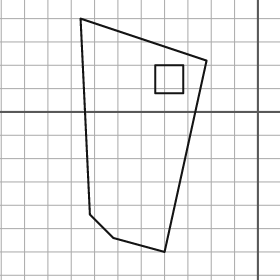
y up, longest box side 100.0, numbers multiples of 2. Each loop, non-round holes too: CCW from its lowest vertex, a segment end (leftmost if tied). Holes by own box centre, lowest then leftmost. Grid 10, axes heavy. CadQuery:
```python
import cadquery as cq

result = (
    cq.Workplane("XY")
    .moveTo(-40.0, -60.0)
    .lineTo(-22.0, 22.0)
    .lineTo(-76.0, 40.0)
    .lineTo(-72.0, -44.0)
    .lineTo(-62.0, -54.0)
    .close()
    .moveTo(-44.0, 8.0)
    .lineTo(-32.0, 8.0)
    .lineTo(-32.0, 20.0)
    .lineTo(-44.0, 20.0)
    .close()
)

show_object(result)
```